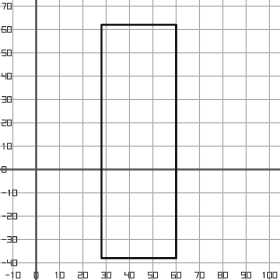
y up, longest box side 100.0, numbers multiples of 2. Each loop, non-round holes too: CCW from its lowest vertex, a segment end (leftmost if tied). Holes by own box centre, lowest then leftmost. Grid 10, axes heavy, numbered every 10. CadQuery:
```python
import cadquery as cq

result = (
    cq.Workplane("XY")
    .moveTo(28.0, -38.0)
    .lineTo(60.0, -38.0)
    .lineTo(60.0, 62.0)
    .lineTo(28.0, 62.0)
    .close()
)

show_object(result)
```